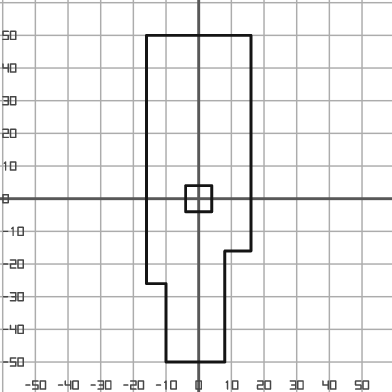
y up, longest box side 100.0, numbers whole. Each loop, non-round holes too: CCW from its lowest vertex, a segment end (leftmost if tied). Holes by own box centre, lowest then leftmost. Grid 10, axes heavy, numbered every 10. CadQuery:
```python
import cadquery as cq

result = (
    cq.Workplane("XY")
    .moveTo(-10.0, -50.0)
    .lineTo(8.0, -50.0)
    .lineTo(8.0, -16.0)
    .lineTo(16.0, -16.0)
    .lineTo(16.0, 50.0)
    .lineTo(-16.0, 50.0)
    .lineTo(-16.0, -26.0)
    .lineTo(-10.0, -26.0)
    .close()
    .moveTo(-4.0, -4.0)
    .lineTo(4.0, -4.0)
    .lineTo(4.0, 4.0)
    .lineTo(-4.0, 4.0)
    .close()
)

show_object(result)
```